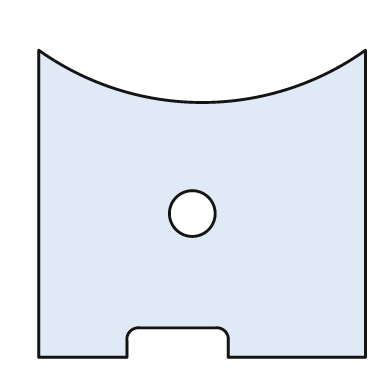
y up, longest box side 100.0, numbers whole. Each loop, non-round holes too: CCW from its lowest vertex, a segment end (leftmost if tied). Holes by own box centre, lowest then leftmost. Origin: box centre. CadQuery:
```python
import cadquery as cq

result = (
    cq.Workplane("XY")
    .moveTo(-50.0, -47.0)
    .lineTo(-23.0, -47.0)
    .lineTo(-23.0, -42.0)
    .threePointArc((-22.0, -39.0), (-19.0, -38.0))
    .lineTo(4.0, -38.0)
    .threePointArc((7.0, -39.0), (8.0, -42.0))
    .lineTo(8.0, -47.0)
    .lineTo(50.0, -47.0)
    .lineTo(50.0, 47.0)
    .threePointArc((0.0, 31.0), (-50.0, 47.0))
    .close()
    .moveTo(-3.0, -3.0)
    .circle(7.0)
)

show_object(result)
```